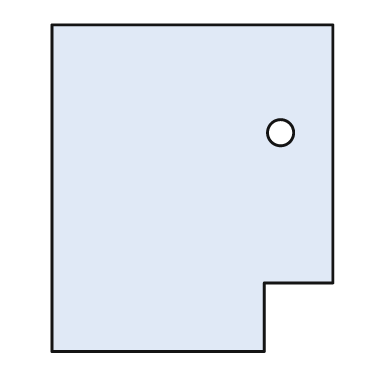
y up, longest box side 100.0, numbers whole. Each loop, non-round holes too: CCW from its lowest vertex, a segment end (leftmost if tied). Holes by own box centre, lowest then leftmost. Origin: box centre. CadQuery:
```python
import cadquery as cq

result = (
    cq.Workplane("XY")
    .moveTo(-43.0, -50.0)
    .lineTo(22.0, -50.0)
    .lineTo(22.0, -29.0)
    .lineTo(43.0, -29.0)
    .lineTo(43.0, 50.0)
    .lineTo(-43.0, 50.0)
    .close()
    .moveTo(27.0, 17.0)
    .circle(4.0)
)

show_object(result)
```